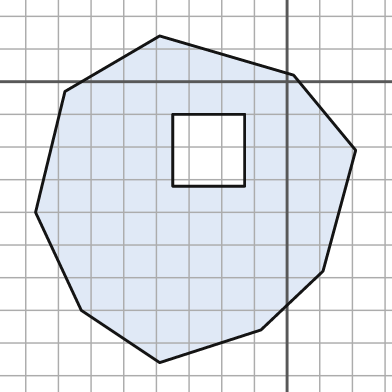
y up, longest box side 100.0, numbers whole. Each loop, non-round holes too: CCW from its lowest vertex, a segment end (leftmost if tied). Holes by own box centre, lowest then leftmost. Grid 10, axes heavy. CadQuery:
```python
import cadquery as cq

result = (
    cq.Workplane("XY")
    .moveTo(-39.0, -86.0)
    .lineTo(-8.0, -76.0)
    .lineTo(11.0, -58.0)
    .lineTo(21.0, -21.0)
    .lineTo(2.0, 2.0)
    .lineTo(-39.0, 14.0)
    .lineTo(-68.0, -3.0)
    .lineTo(-77.0, -40.0)
    .lineTo(-63.0, -70.0)
    .close()
    .moveTo(-35.0, -32.0)
    .lineTo(-13.0, -32.0)
    .lineTo(-13.0, -10.0)
    .lineTo(-35.0, -10.0)
    .close()
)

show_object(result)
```